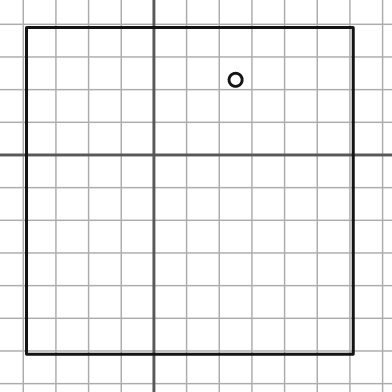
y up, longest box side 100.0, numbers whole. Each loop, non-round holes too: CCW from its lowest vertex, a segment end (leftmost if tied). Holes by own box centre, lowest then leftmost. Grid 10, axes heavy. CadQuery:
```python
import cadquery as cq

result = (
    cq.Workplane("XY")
    .moveTo(-39.0, -61.0)
    .lineTo(61.0, -61.0)
    .lineTo(61.0, 39.0)
    .lineTo(-39.0, 39.0)
    .close()
    .moveTo(25.0, 23.0)
    .circle(2.0)
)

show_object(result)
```